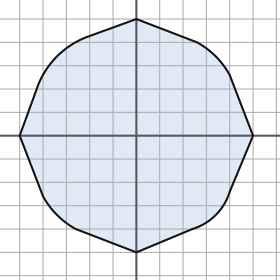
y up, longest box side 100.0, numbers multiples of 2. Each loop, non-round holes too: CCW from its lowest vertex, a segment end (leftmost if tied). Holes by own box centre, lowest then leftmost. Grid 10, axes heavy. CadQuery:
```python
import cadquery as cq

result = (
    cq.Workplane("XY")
    .moveTo(0.0, -50.0)
    .lineTo(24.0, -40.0)
    .threePointArc((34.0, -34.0), (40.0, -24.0))
    .lineTo(50.0, 0.0)
    .lineTo(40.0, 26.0)
    .threePointArc((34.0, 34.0), (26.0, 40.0))
    .lineTo(0.0, 50.0)
    .lineTo(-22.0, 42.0)
    .threePointArc((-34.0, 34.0), (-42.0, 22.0))
    .lineTo(-50.0, 0.0)
    .lineTo(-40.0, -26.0)
    .threePointArc((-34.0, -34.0), (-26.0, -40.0))
    .close()
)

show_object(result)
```